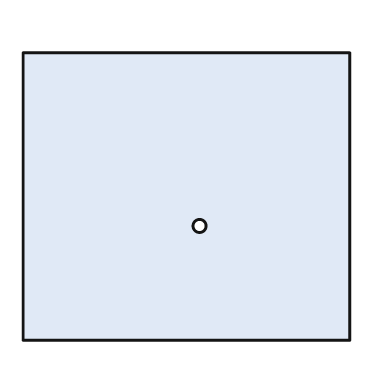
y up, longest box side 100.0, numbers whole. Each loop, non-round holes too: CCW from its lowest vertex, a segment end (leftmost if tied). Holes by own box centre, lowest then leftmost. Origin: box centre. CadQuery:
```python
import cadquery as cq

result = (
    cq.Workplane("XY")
    .moveTo(-50.0, -44.0)
    .lineTo(50.0, -44.0)
    .lineTo(50.0, 44.0)
    .lineTo(-50.0, 44.0)
    .close()
    .moveTo(4.0, -9.0)
    .circle(2.0)
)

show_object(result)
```